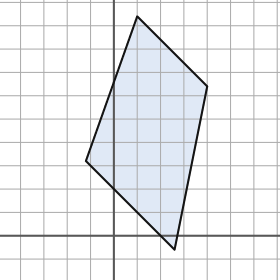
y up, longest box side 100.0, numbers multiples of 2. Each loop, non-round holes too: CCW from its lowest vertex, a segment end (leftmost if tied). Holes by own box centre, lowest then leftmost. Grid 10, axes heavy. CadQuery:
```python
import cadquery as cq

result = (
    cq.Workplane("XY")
    .moveTo(26.0, -6.0)
    .lineTo(40.0, 64.0)
    .lineTo(10.0, 94.0)
    .lineTo(-12.0, 32.0)
    .close()
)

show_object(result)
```